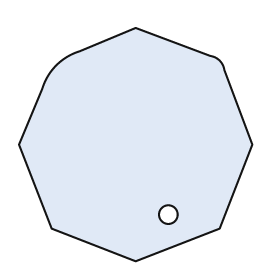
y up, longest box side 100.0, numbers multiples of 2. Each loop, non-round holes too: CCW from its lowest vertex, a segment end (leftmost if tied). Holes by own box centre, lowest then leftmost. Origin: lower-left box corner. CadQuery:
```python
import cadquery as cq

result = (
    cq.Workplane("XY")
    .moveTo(50.0, 0.0)
    .lineTo(86.0, 14.0)
    .lineTo(100.0, 50.0)
    .lineTo(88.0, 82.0)
    .threePointArc((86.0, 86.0), (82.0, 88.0))
    .lineTo(50.0, 100.0)
    .lineTo(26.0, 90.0)
    .threePointArc((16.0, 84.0), (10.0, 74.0))
    .lineTo(0.0, 50.0)
    .lineTo(14.0, 14.0)
    .close()
    .moveTo(64.0, 20.0)
    .circle(4.0)
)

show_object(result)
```